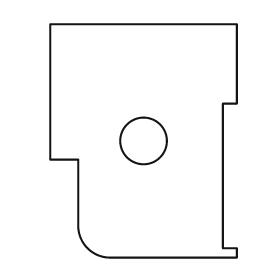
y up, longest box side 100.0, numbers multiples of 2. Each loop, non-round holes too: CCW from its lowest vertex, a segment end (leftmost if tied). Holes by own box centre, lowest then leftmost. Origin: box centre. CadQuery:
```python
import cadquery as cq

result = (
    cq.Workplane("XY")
    .moveTo(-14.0, -50.0)
    .lineTo(40.0, -50.0)
    .lineTo(40.0, -46.0)
    .lineTo(34.0, -46.0)
    .lineTo(34.0, 16.0)
    .lineTo(40.0, 16.0)
    .lineTo(40.0, 50.0)
    .lineTo(-40.0, 50.0)
    .lineTo(-40.0, -8.0)
    .lineTo(-28.0, -8.0)
    .lineTo(-28.0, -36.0)
    .threePointArc((-24.0, -46.0), (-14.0, -50.0))
    .close()
    .moveTo(0.0, 0.0)
    .circle(10.0)
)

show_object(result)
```